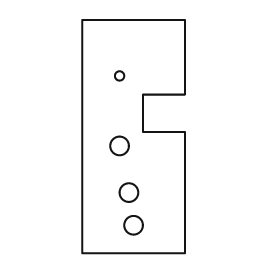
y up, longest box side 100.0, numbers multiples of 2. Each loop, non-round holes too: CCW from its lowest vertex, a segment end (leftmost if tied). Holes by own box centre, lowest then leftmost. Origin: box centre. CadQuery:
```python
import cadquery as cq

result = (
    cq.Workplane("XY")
    .moveTo(-22.0, -50.0)
    .lineTo(22.0, -50.0)
    .lineTo(22.0, 2.0)
    .lineTo(4.0, 2.0)
    .lineTo(4.0, 18.0)
    .lineTo(22.0, 18.0)
    .lineTo(22.0, 50.0)
    .lineTo(-22.0, 50.0)
    .close()
    .moveTo(0.0, -38.0)
    .circle(4.0)
    .moveTo(-2.0, -24.0)
    .circle(4.0)
    .moveTo(-6.0, -4.0)
    .circle(4.0)
    .moveTo(-6.0, 26.0)
    .circle(2.0)
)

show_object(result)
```